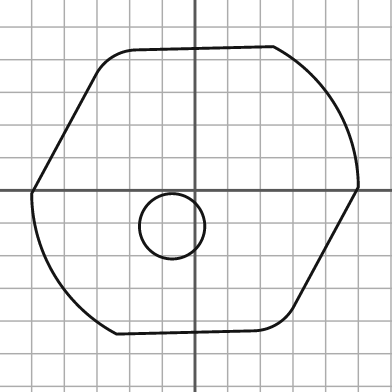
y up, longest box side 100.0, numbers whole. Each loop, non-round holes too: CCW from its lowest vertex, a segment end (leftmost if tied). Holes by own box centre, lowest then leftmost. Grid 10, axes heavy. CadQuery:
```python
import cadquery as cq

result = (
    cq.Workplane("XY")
    .moveTo(-24.0, -44.0)
    .lineTo(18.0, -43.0)
    .threePointArc((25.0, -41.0), (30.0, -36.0))
    .lineTo(50.0, 1.0)
    .threePointArc((43.0, 26.0), (24.0, 44.0))
    .lineTo(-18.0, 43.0)
    .threePointArc((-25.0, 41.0), (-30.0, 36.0))
    .lineTo(-50.0, -1.0)
    .threePointArc((-43.0, -26.0), (-24.0, -44.0))
    .close()
    .moveTo(-7.0, -11.0)
    .circle(10.0)
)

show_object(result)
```